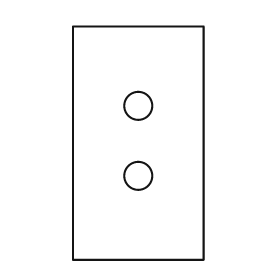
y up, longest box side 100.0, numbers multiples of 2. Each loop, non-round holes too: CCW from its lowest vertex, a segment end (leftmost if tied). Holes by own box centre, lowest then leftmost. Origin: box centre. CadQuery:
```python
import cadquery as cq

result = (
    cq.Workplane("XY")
    .moveTo(-28.0, -50.0)
    .lineTo(28.0, -50.0)
    .lineTo(28.0, 50.0)
    .lineTo(-28.0, 50.0)
    .close()
    .moveTo(0.0, -14.0)
    .circle(6.0)
    .moveTo(0.0, 16.0)
    .circle(6.0)
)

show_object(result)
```